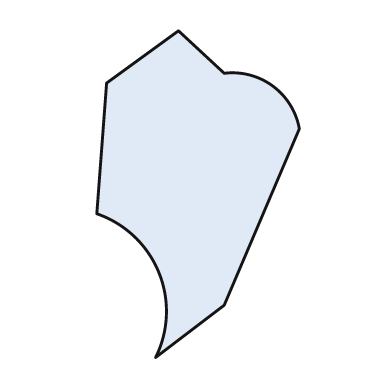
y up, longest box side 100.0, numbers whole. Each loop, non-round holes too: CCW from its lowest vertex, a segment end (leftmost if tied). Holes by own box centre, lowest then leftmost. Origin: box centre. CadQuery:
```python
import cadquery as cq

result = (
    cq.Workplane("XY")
    .moveTo(-13.0, -50.0)
    .lineTo(8.0, -34.0)
    .lineTo(31.0, 20.0)
    .threePointArc((23.0, 33.0), (8.0, 37.0))
    .lineTo(-6.0, 50.0)
    .lineTo(-28.0, 34.0)
    .lineTo(-31.0, -6.0)
    .threePointArc((-12.0, -24.0), (-13.0, -50.0))
    .close()
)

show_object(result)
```